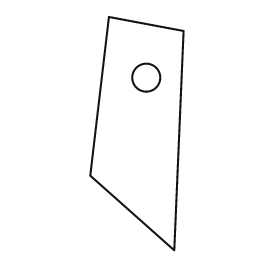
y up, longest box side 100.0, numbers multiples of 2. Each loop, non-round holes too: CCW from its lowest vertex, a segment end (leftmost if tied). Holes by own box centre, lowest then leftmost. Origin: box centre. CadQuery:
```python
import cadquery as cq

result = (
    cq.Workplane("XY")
    .moveTo(16.0, -50.0)
    .lineTo(20.0, 44.0)
    .lineTo(-12.0, 50.0)
    .lineTo(-20.0, -18.0)
    .close()
    .moveTo(4.0, 24.0)
    .circle(6.0)
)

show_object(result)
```